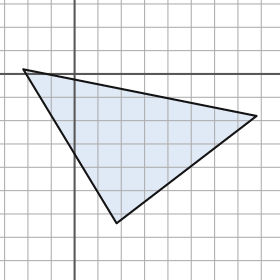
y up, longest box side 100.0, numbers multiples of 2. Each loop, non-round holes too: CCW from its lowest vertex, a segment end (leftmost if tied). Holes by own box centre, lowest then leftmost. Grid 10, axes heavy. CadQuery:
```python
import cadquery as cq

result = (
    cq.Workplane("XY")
    .moveTo(18.0, -64.0)
    .lineTo(78.0, -18.0)
    .lineTo(-22.0, 2.0)
    .close()
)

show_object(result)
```